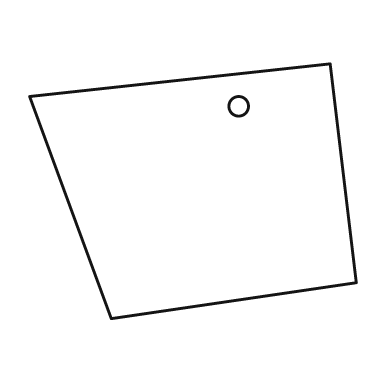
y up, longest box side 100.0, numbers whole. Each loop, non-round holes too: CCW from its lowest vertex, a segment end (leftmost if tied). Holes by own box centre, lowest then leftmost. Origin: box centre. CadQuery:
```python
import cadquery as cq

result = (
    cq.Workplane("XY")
    .moveTo(-25.0, -39.0)
    .lineTo(50.0, -28.0)
    .lineTo(42.0, 39.0)
    .lineTo(-50.0, 29.0)
    .close()
    .moveTo(14.0, 26.0)
    .circle(3.0)
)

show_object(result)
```